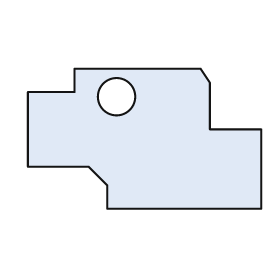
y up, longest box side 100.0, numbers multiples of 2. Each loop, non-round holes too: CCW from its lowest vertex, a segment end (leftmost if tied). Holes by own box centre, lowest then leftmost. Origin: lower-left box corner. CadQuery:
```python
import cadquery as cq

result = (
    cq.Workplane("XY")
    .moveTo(34.0, 0.0)
    .lineTo(100.0, 0.0)
    .lineTo(100.0, 34.0)
    .lineTo(78.0, 34.0)
    .lineTo(78.0, 54.0)
    .lineTo(74.0, 60.0)
    .lineTo(20.0, 60.0)
    .lineTo(20.0, 50.0)
    .lineTo(0.0, 50.0)
    .lineTo(0.0, 18.0)
    .lineTo(26.0, 18.0)
    .lineTo(34.0, 10.0)
    .close()
    .moveTo(38.0, 48.0)
    .circle(8.0)
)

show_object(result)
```